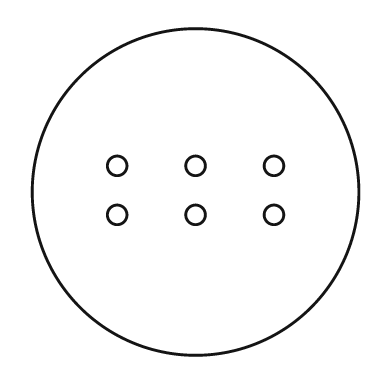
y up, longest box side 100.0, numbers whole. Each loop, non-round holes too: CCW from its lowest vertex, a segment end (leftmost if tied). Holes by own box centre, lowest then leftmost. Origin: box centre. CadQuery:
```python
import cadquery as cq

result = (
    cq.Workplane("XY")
    .moveTo(0.0, 0.0)
    .circle(50.0)
    .moveTo(-24.0, -7.0)
    .circle(3.0)
    .moveTo(0.0, -7.0)
    .circle(3.0)
    .moveTo(24.0, -7.0)
    .circle(3.0)
    .moveTo(-24.0, 8.0)
    .circle(3.0)
    .moveTo(0.0, 8.0)
    .circle(3.0)
    .moveTo(24.0, 8.0)
    .circle(3.0)
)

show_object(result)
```